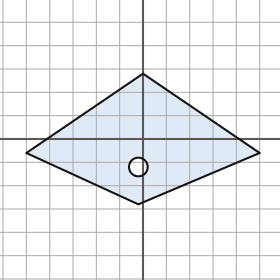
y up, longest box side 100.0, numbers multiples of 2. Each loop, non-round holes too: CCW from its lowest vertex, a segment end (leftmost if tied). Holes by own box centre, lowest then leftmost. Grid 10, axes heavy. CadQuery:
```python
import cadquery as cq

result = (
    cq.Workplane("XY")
    .moveTo(-2.0, -28.0)
    .lineTo(50.0, -6.0)
    .lineTo(0.0, 28.0)
    .lineTo(-50.0, -6.0)
    .close()
    .moveTo(-2.0, -12.0)
    .circle(4.0)
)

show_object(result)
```